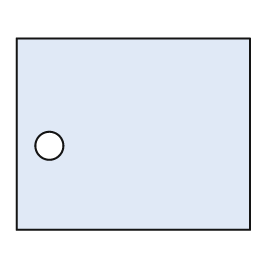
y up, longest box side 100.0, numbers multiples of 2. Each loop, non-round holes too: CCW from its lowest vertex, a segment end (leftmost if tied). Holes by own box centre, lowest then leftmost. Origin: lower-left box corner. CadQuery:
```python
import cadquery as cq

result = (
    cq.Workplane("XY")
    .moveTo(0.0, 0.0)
    .lineTo(100.0, 0.0)
    .lineTo(100.0, 82.0)
    .lineTo(0.0, 82.0)
    .close()
    .moveTo(14.0, 36.0)
    .circle(6.0)
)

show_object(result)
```